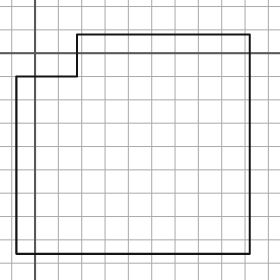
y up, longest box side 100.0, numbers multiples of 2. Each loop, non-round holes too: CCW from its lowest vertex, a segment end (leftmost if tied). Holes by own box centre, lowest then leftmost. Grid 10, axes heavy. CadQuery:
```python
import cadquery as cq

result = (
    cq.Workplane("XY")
    .moveTo(-8.0, -86.0)
    .lineTo(92.0, -86.0)
    .lineTo(92.0, 8.0)
    .lineTo(18.0, 8.0)
    .lineTo(18.0, -10.0)
    .lineTo(-8.0, -10.0)
    .close()
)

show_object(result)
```